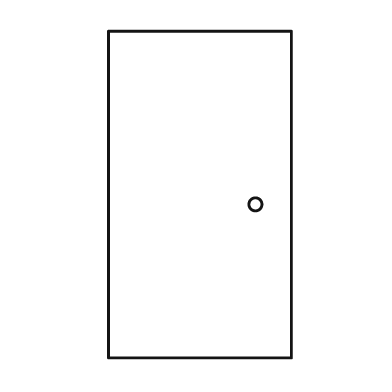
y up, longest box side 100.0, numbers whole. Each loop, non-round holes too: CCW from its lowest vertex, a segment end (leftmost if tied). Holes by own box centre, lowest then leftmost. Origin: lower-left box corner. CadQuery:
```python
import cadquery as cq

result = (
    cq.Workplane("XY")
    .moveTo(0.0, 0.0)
    .lineTo(56.0, 0.0)
    .lineTo(56.0, 100.0)
    .lineTo(0.0, 100.0)
    .close()
    .moveTo(45.0, 47.0)
    .circle(2.0)
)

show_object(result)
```